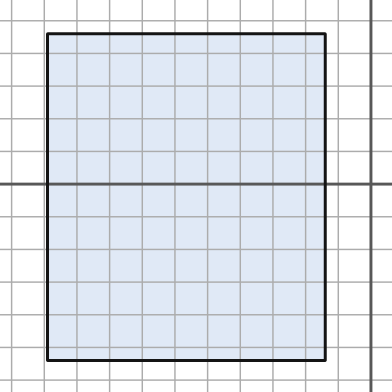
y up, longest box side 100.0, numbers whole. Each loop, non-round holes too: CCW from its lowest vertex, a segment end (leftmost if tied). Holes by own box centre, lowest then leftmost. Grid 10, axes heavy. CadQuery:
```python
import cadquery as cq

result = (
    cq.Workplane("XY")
    .moveTo(-99.0, -54.0)
    .lineTo(-14.0, -54.0)
    .lineTo(-14.0, 46.0)
    .lineTo(-99.0, 46.0)
    .close()
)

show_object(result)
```